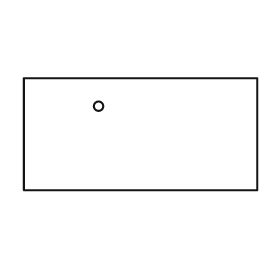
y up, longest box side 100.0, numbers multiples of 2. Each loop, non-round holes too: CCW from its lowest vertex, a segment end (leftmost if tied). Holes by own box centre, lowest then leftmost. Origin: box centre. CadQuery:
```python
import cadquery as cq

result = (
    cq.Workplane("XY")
    .moveTo(-50.0, -24.0)
    .lineTo(50.0, -24.0)
    .lineTo(50.0, 24.0)
    .lineTo(-50.0, 24.0)
    .close()
    .moveTo(-18.0, 12.0)
    .circle(2.0)
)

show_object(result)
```